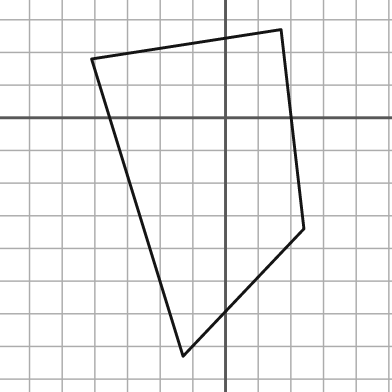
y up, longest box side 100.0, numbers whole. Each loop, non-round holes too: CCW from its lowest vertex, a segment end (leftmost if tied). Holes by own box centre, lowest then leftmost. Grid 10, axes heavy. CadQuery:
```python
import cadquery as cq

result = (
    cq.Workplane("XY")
    .moveTo(-13.0, -73.0)
    .lineTo(24.0, -34.0)
    .lineTo(17.0, 27.0)
    .lineTo(-41.0, 18.0)
    .close()
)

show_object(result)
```